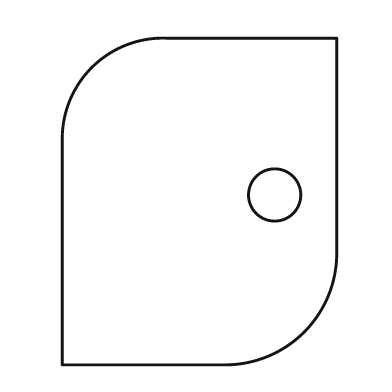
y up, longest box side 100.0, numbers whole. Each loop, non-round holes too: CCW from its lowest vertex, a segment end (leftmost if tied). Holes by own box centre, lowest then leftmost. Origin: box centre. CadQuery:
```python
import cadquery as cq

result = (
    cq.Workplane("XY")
    .moveTo(-42.0, -50.0)
    .lineTo(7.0, -50.0)
    .threePointArc((32.0, -40.0), (42.0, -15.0))
    .lineTo(42.0, 50.0)
    .lineTo(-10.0, 50.0)
    .threePointArc((-33.0, 41.0), (-42.0, 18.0))
    .close()
    .moveTo(23.0, 2.0)
    .circle(8.0)
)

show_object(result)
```